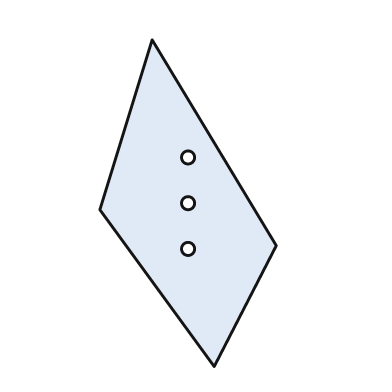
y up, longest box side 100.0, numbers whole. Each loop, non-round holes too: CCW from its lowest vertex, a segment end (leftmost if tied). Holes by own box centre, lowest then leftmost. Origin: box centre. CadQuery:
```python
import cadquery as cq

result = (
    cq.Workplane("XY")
    .moveTo(8.0, -50.0)
    .lineTo(27.0, -13.0)
    .lineTo(-11.0, 50.0)
    .lineTo(-27.0, -2.0)
    .close()
    .moveTo(0.0, -14.0)
    .circle(2.0)
    .moveTo(0.0, 0.0)
    .circle(2.0)
    .moveTo(0.0, 14.0)
    .circle(2.0)
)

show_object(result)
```